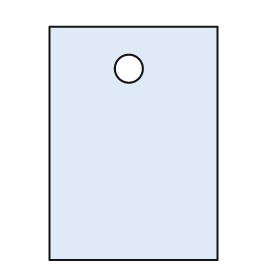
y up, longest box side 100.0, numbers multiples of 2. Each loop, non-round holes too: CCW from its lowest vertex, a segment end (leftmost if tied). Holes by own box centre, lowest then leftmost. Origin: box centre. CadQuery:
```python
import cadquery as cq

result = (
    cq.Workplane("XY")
    .moveTo(-36.0, -50.0)
    .lineTo(36.0, -50.0)
    .lineTo(36.0, 50.0)
    .lineTo(-36.0, 50.0)
    .close()
    .moveTo(-2.0, 32.0)
    .circle(6.0)
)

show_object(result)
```